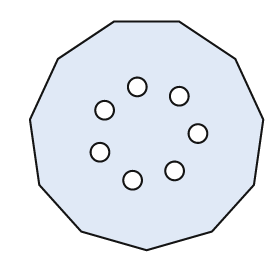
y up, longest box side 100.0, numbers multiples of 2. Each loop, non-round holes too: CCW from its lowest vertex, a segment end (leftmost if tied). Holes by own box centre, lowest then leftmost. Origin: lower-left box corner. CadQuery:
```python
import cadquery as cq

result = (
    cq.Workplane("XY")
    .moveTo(50.0, 0.0)
    .lineTo(78.0, 8.0)
    .lineTo(96.0, 28.0)
    .lineTo(100.0, 56.0)
    .lineTo(88.0, 82.0)
    .lineTo(64.0, 98.0)
    .lineTo(36.0, 98.0)
    .lineTo(12.0, 82.0)
    .lineTo(0.0, 56.0)
    .lineTo(4.0, 28.0)
    .lineTo(22.0, 8.0)
    .close()
    .moveTo(44.0, 30.0)
    .circle(4.0)
    .moveTo(62.0, 34.0)
    .circle(4.0)
    .moveTo(30.0, 42.0)
    .circle(4.0)
    .moveTo(72.0, 50.0)
    .circle(4.0)
    .moveTo(32.0, 60.0)
    .circle(4.0)
    .moveTo(64.0, 66.0)
    .circle(4.0)
    .moveTo(46.0, 70.0)
    .circle(4.0)
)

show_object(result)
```